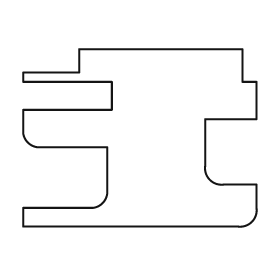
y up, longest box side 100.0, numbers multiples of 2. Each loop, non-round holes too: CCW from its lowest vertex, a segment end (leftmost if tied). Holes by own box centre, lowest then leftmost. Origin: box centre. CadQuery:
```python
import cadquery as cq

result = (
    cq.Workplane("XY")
    .moveTo(-50.0, -38.0)
    .lineTo(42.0, -38.0)
    .threePointArc((48.0, -36.0), (50.0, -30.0))
    .lineTo(50.0, -20.0)
    .lineTo(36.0, -20.0)
    .threePointArc((30.0, -18.0), (28.0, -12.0))
    .lineTo(28.0, 8.0)
    .lineTo(50.0, 8.0)
    .lineTo(50.0, 24.0)
    .lineTo(44.0, 24.0)
    .lineTo(44.0, 38.0)
    .lineTo(-26.0, 38.0)
    .lineTo(-26.0, 28.0)
    .lineTo(-50.0, 28.0)
    .lineTo(-50.0, 24.0)
    .lineTo(-12.0, 24.0)
    .lineTo(-12.0, 12.0)
    .lineTo(-50.0, 12.0)
    .lineTo(-50.0, 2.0)
    .threePointArc((-48.0, -2.0), (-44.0, -4.0))
    .lineTo(-14.0, -4.0)
    .lineTo(-14.0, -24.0)
    .threePointArc((-16.0, -28.0), (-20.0, -30.0))
    .lineTo(-50.0, -30.0)
    .close()
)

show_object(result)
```